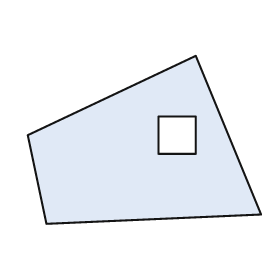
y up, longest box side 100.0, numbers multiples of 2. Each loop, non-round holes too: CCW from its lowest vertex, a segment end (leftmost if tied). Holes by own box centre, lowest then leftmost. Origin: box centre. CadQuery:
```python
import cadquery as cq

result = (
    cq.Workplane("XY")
    .moveTo(-42.0, -36.0)
    .lineTo(50.0, -32.0)
    .lineTo(22.0, 36.0)
    .lineTo(-50.0, 2.0)
    .close()
    .moveTo(6.0, -6.0)
    .lineTo(22.0, -6.0)
    .lineTo(22.0, 10.0)
    .lineTo(6.0, 10.0)
    .close()
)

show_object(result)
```